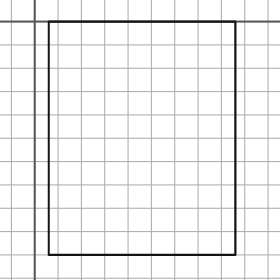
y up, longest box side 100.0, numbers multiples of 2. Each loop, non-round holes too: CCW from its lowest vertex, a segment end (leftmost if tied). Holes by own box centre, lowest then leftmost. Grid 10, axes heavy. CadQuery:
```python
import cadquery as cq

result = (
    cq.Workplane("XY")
    .moveTo(6.0, -100.0)
    .lineTo(86.0, -100.0)
    .lineTo(86.0, 0.0)
    .lineTo(6.0, 0.0)
    .close()
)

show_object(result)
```